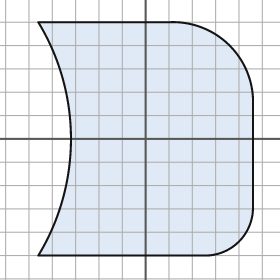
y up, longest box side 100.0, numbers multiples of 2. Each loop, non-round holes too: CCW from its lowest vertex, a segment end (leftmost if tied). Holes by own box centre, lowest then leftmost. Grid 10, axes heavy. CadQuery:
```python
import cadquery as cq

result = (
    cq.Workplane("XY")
    .moveTo(-46.0, -50.0)
    .lineTo(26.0, -50.0)
    .threePointArc((40.0, -44.0), (46.0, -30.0))
    .lineTo(46.0, 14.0)
    .threePointArc((36.0, 40.0), (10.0, 50.0))
    .lineTo(-46.0, 50.0)
    .threePointArc((-32.0, 0.0), (-46.0, -50.0))
    .close()
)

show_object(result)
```